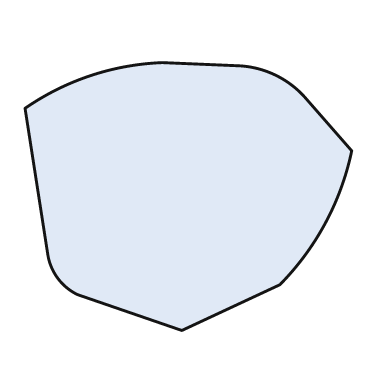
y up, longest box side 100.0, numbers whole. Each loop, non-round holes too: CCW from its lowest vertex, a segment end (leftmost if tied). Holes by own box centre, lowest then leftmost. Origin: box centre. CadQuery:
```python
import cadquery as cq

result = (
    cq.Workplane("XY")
    .moveTo(-2.0, -41.0)
    .lineTo(28.0, -27.0)
    .threePointArc((42.0, -8.0), (50.0, 14.0))
    .lineTo(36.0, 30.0)
    .threePointArc((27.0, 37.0), (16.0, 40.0))
    .lineTo(-8.0, 41.0)
    .threePointArc((-30.0, 37.0), (-50.0, 27.0))
    .lineTo(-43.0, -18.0)
    .threePointArc((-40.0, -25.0), (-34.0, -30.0))
    .close()
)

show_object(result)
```